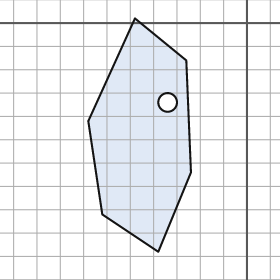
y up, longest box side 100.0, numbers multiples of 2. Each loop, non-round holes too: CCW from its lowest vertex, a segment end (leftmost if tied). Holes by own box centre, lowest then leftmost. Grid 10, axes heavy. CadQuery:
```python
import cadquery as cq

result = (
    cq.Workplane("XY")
    .moveTo(-38.0, -98.0)
    .lineTo(-24.0, -64.0)
    .lineTo(-26.0, -16.0)
    .lineTo(-48.0, 2.0)
    .lineTo(-68.0, -42.0)
    .lineTo(-62.0, -82.0)
    .close()
    .moveTo(-34.0, -34.0)
    .circle(4.0)
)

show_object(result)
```